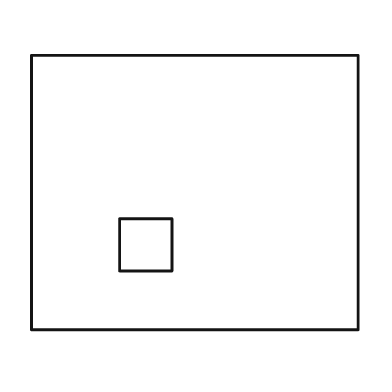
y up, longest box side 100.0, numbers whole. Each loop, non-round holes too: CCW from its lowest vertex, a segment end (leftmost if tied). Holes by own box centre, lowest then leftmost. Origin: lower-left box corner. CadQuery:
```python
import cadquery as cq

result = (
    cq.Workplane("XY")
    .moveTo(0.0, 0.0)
    .lineTo(100.0, 0.0)
    .lineTo(100.0, 84.0)
    .lineTo(0.0, 84.0)
    .close()
    .moveTo(27.0, 18.0)
    .lineTo(43.0, 18.0)
    .lineTo(43.0, 34.0)
    .lineTo(27.0, 34.0)
    .close()
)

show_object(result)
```